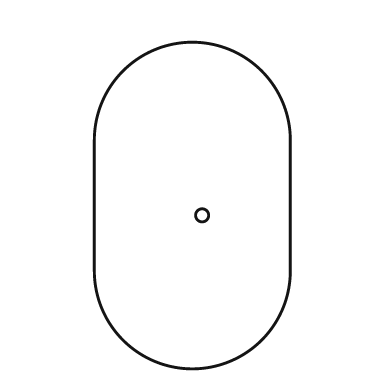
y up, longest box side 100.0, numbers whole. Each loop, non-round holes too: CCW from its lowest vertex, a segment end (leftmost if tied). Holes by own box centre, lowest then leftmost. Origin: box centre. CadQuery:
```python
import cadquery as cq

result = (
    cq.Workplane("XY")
    .moveTo(-30.0, -20.0)
    .threePointArc((0.0, -50.0), (30.0, -20.0))
    .lineTo(30.0, 20.0)
    .threePointArc((0.0, 50.0), (-30.0, 20.0))
    .close()
    .moveTo(3.0, -3.0)
    .circle(2.0)
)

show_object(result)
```